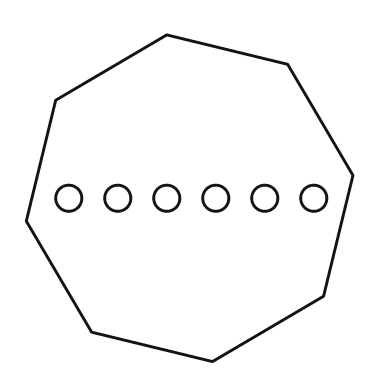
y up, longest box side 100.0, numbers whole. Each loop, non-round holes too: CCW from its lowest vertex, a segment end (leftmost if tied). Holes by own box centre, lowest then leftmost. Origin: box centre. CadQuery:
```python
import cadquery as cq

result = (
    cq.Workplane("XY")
    .moveTo(7.0, -50.0)
    .lineTo(41.0, -30.0)
    .lineTo(50.0, 7.0)
    .lineTo(30.0, 41.0)
    .lineTo(-7.0, 50.0)
    .lineTo(-41.0, 30.0)
    .lineTo(-50.0, -7.0)
    .lineTo(-30.0, -41.0)
    .close()
    .moveTo(-37.0, 0.0)
    .circle(4.0)
    .moveTo(-22.0, 0.0)
    .circle(4.0)
    .moveTo(-7.0, 0.0)
    .circle(4.0)
    .moveTo(8.0, 0.0)
    .circle(4.0)
    .moveTo(23.0, 0.0)
    .circle(4.0)
    .moveTo(38.0, 0.0)
    .circle(4.0)
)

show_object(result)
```